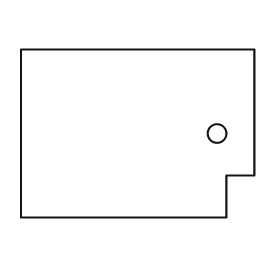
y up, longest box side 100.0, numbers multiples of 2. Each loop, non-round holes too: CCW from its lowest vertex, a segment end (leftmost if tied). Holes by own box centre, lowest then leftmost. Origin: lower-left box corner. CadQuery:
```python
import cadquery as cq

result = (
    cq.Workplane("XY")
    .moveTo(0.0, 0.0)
    .lineTo(88.0, 0.0)
    .lineTo(88.0, 18.0)
    .lineTo(100.0, 18.0)
    .lineTo(100.0, 72.0)
    .lineTo(0.0, 72.0)
    .close()
    .moveTo(84.0, 36.0)
    .circle(4.0)
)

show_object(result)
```